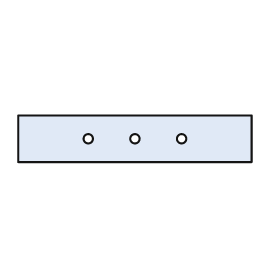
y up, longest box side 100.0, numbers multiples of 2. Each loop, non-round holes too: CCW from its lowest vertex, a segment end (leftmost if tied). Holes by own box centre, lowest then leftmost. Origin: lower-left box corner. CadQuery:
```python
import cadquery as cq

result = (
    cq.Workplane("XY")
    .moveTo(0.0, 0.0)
    .lineTo(100.0, 0.0)
    .lineTo(100.0, 20.0)
    .lineTo(0.0, 20.0)
    .close()
    .moveTo(30.0, 10.0)
    .circle(2.0)
    .moveTo(50.0, 10.0)
    .circle(2.0)
    .moveTo(70.0, 10.0)
    .circle(2.0)
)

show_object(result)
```